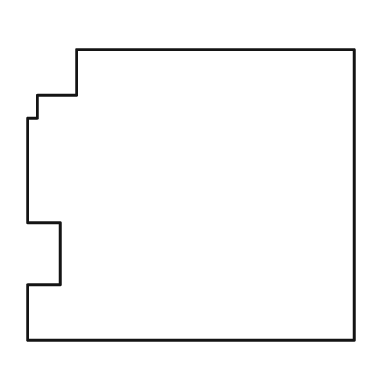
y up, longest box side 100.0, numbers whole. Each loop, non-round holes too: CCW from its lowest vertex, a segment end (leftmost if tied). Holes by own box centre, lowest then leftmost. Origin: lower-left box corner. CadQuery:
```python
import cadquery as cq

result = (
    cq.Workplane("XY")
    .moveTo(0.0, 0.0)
    .lineTo(100.0, 0.0)
    .lineTo(100.0, 89.0)
    .lineTo(15.0, 89.0)
    .lineTo(15.0, 75.0)
    .lineTo(3.0, 75.0)
    .lineTo(3.0, 68.0)
    .lineTo(0.0, 68.0)
    .lineTo(0.0, 36.0)
    .lineTo(10.0, 36.0)
    .lineTo(10.0, 17.0)
    .lineTo(0.0, 17.0)
    .close()
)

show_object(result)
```